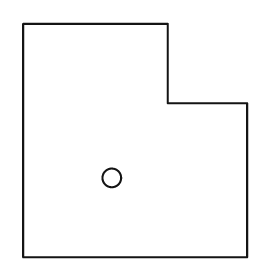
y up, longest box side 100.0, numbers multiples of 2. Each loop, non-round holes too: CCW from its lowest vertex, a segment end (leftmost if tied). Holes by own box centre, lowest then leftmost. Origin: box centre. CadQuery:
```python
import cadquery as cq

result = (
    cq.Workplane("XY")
    .moveTo(-48.0, -50.0)
    .lineTo(48.0, -50.0)
    .lineTo(48.0, 16.0)
    .lineTo(14.0, 16.0)
    .lineTo(14.0, 50.0)
    .lineTo(-48.0, 50.0)
    .close()
    .moveTo(-10.0, -16.0)
    .circle(4.0)
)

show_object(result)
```